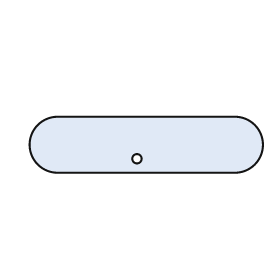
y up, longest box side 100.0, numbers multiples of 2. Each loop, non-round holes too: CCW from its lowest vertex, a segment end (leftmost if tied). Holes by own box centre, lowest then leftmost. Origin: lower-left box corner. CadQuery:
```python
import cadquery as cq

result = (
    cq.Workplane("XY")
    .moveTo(12.0, 0.0)
    .lineTo(88.0, 0.0)
    .threePointArc((100.0, 12.0), (88.0, 24.0))
    .lineTo(12.0, 24.0)
    .threePointArc((0.0, 12.0), (12.0, 0.0))
    .close()
    .moveTo(46.0, 6.0)
    .circle(2.0)
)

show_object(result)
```